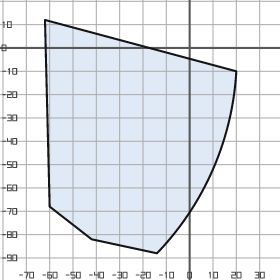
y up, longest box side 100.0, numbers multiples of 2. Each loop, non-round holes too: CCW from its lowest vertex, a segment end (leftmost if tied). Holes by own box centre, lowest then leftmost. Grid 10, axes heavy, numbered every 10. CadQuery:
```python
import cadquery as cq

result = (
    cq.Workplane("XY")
    .moveTo(-14.0, -88.0)
    .threePointArc((10.0, -52.0), (20.0, -10.0))
    .lineTo(-62.0, 12.0)
    .lineTo(-60.0, -68.0)
    .lineTo(-42.0, -82.0)
    .close()
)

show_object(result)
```